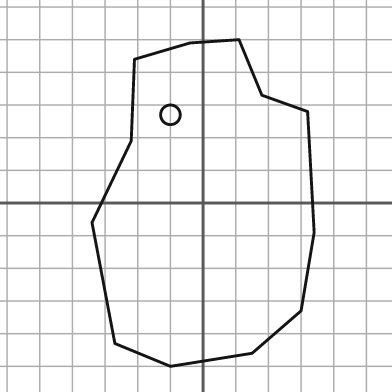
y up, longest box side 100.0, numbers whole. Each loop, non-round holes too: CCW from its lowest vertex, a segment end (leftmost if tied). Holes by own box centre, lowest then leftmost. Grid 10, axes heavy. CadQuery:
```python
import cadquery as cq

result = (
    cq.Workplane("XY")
    .moveTo(-10.0, -50.0)
    .lineTo(15.0, -46.0)
    .lineTo(30.0, -33.0)
    .lineTo(34.0, -9.0)
    .lineTo(32.0, 28.0)
    .lineTo(18.0, 33.0)
    .lineTo(11.0, 50.0)
    .lineTo(-4.0, 49.0)
    .lineTo(-21.0, 44.0)
    .lineTo(-22.0, 19.0)
    .lineTo(-34.0, -6.0)
    .lineTo(-27.0, -43.0)
    .close()
    .moveTo(-10.0, 27.0)
    .circle(3.0)
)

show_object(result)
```